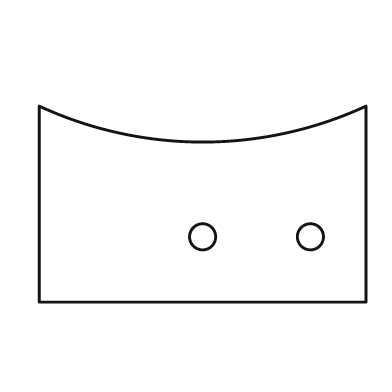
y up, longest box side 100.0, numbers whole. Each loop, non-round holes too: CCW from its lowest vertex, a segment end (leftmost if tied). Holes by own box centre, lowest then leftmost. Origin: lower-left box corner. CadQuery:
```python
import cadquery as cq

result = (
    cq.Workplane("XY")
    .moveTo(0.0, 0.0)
    .lineTo(100.0, 0.0)
    .lineTo(100.0, 60.0)
    .threePointArc((50.0, 49.0), (0.0, 60.0))
    .close()
    .moveTo(50.0, 20.0)
    .circle(4.0)
    .moveTo(83.0, 20.0)
    .circle(4.0)
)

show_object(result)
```